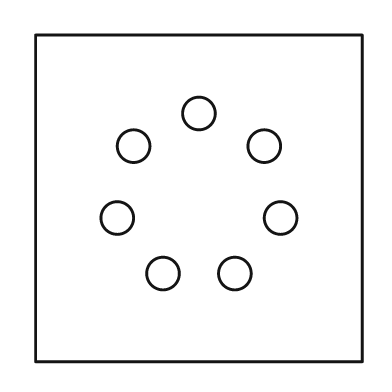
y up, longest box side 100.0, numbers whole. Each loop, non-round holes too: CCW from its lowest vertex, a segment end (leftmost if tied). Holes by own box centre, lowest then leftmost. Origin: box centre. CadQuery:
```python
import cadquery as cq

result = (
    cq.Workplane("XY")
    .moveTo(-50.0, -50.0)
    .lineTo(50.0, -50.0)
    .lineTo(50.0, 50.0)
    .lineTo(-50.0, 50.0)
    .close()
    .moveTo(-11.0, -23.0)
    .circle(5.0)
    .moveTo(11.0, -23.0)
    .circle(5.0)
    .moveTo(-25.0, -6.0)
    .circle(5.0)
    .moveTo(25.0, -6.0)
    .circle(5.0)
    .moveTo(-20.0, 16.0)
    .circle(5.0)
    .moveTo(20.0, 16.0)
    .circle(5.0)
    .moveTo(0.0, 26.0)
    .circle(5.0)
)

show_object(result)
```